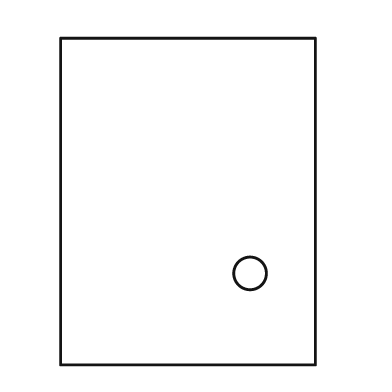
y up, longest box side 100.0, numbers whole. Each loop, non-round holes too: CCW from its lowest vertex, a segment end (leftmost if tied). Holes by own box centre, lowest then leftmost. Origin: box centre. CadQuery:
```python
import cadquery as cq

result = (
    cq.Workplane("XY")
    .moveTo(-39.0, -50.0)
    .lineTo(39.0, -50.0)
    .lineTo(39.0, 50.0)
    .lineTo(-39.0, 50.0)
    .close()
    .moveTo(19.0, -22.0)
    .circle(5.0)
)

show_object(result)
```